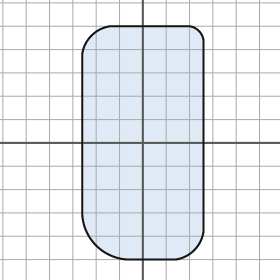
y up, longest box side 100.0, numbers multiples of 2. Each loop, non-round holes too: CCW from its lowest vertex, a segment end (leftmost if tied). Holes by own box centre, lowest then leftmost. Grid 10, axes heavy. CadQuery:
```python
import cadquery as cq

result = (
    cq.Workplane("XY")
    .moveTo(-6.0, -50.0)
    .lineTo(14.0, -50.0)
    .threePointArc((22.0, -46.0), (26.0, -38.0))
    .lineTo(26.0, 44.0)
    .threePointArc((24.0, 48.0), (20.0, 50.0))
    .lineTo(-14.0, 50.0)
    .threePointArc((-22.0, 46.0), (-26.0, 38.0))
    .lineTo(-26.0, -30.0)
    .threePointArc((-20.0, -44.0), (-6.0, -50.0))
    .close()
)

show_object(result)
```